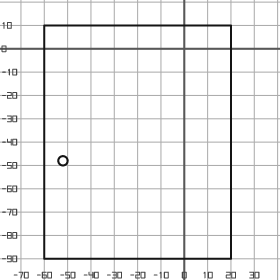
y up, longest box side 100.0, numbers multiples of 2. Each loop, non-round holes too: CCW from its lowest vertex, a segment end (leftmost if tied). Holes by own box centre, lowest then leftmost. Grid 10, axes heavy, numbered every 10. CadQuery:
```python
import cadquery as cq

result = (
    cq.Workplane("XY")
    .moveTo(-60.0, -90.0)
    .lineTo(20.0, -90.0)
    .lineTo(20.0, 10.0)
    .lineTo(-60.0, 10.0)
    .close()
    .moveTo(-52.0, -48.0)
    .circle(2.0)
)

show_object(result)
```